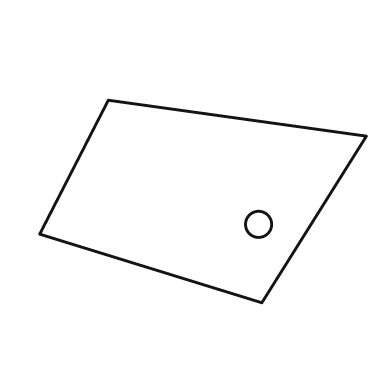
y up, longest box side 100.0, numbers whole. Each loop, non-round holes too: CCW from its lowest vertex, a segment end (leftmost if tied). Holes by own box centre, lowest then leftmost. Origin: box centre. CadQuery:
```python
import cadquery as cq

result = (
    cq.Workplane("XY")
    .moveTo(18.0, -31.0)
    .lineTo(50.0, 20.0)
    .lineTo(-29.0, 31.0)
    .lineTo(-50.0, -10.0)
    .close()
    .moveTo(17.0, -7.0)
    .circle(4.0)
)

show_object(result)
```